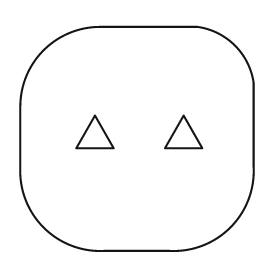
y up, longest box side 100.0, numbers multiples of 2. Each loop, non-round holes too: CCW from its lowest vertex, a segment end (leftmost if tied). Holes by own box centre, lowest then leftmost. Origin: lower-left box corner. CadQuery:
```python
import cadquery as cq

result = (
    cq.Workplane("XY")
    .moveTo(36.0, 0.0)
    .lineTo(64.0, 0.0)
    .threePointArc((90.0, 10.0), (100.0, 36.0))
    .lineTo(100.0, 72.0)
    .threePointArc((92.0, 88.0), (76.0, 96.0))
    .lineTo(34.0, 96.0)
    .threePointArc((10.0, 86.0), (0.0, 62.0))
    .lineTo(0.0, 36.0)
    .threePointArc((10.0, 10.0), (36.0, 0.0))
    .close()
    .moveTo(24.0, 44.0)
    .lineTo(40.0, 44.0)
    .lineTo(32.0, 58.0)
    .close()
    .moveTo(62.0, 44.0)
    .lineTo(78.0, 44.0)
    .lineTo(70.0, 58.0)
    .close()
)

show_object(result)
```